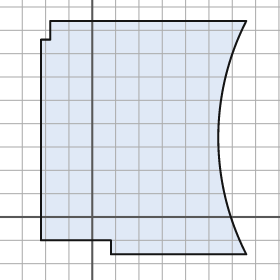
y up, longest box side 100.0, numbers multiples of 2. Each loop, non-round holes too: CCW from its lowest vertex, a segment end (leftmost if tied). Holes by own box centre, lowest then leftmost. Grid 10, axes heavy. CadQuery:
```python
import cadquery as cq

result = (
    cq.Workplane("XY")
    .moveTo(8.0, -16.0)
    .lineTo(66.0, -16.0)
    .threePointArc((54.0, 34.0), (66.0, 84.0))
    .lineTo(-18.0, 84.0)
    .lineTo(-18.0, 76.0)
    .lineTo(-22.0, 76.0)
    .lineTo(-22.0, -10.0)
    .lineTo(8.0, -10.0)
    .close()
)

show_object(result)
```